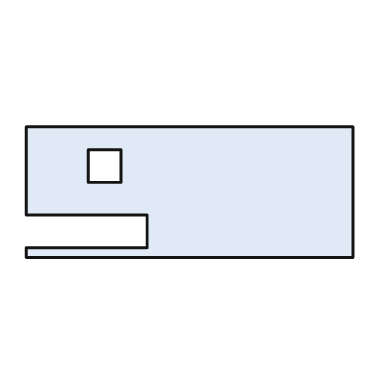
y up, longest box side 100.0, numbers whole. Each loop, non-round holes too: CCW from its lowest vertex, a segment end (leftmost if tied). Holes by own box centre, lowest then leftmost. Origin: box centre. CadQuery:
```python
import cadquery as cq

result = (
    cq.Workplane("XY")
    .moveTo(-50.0, -20.0)
    .lineTo(50.0, -20.0)
    .lineTo(50.0, 20.0)
    .lineTo(-50.0, 20.0)
    .lineTo(-50.0, -7.0)
    .lineTo(-13.0, -7.0)
    .lineTo(-13.0, -17.0)
    .lineTo(-50.0, -17.0)
    .close()
    .moveTo(-31.0, 3.0)
    .lineTo(-21.0, 3.0)
    .lineTo(-21.0, 13.0)
    .lineTo(-31.0, 13.0)
    .close()
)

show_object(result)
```